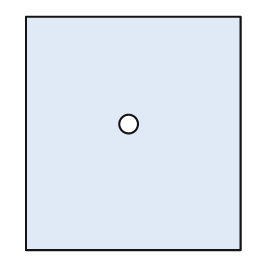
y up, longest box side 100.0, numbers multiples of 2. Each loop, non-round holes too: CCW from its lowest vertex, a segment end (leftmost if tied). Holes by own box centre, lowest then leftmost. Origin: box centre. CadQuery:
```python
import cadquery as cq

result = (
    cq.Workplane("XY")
    .moveTo(-46.0, -50.0)
    .lineTo(46.0, -50.0)
    .lineTo(46.0, 50.0)
    .lineTo(-46.0, 50.0)
    .close()
    .moveTo(-2.0, 4.0)
    .circle(4.0)
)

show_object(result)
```